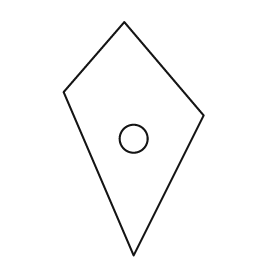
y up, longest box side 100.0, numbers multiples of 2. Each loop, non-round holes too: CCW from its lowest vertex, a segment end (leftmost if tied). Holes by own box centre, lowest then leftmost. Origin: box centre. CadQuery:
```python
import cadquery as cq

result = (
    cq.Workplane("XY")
    .moveTo(0.0, -50.0)
    .lineTo(30.0, 10.0)
    .lineTo(-4.0, 50.0)
    .lineTo(-30.0, 20.0)
    .close()
    .moveTo(0.0, 0.0)
    .circle(6.0)
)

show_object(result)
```